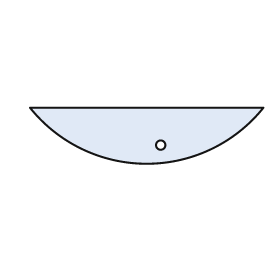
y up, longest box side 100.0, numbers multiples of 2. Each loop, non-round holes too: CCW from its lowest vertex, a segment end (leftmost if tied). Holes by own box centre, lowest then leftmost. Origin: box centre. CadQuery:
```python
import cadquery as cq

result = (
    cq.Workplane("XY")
    .moveTo(-50.0, 12.0)
    .threePointArc((0.0, -12.0), (50.0, 12.0))
    .close()
    .moveTo(6.0, -4.0)
    .circle(2.0)
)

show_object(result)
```